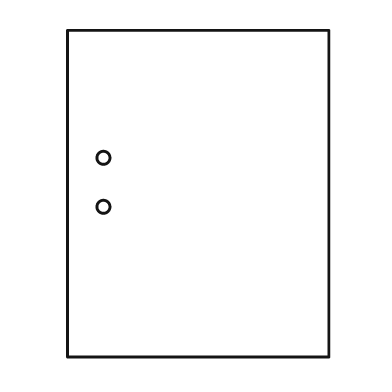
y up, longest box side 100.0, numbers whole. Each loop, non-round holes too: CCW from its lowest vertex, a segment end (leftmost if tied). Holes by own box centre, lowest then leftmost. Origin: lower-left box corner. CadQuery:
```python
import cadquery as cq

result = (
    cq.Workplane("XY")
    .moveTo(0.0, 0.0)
    .lineTo(80.0, 0.0)
    .lineTo(80.0, 100.0)
    .lineTo(0.0, 100.0)
    .close()
    .moveTo(11.0, 46.0)
    .circle(2.0)
    .moveTo(11.0, 61.0)
    .circle(2.0)
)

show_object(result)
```